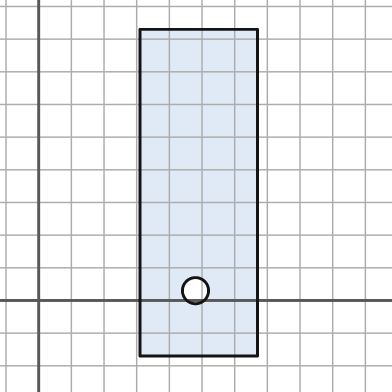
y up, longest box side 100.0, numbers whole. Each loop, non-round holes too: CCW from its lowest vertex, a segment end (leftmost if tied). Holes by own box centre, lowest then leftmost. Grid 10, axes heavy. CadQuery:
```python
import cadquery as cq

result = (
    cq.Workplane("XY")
    .moveTo(31.0, -17.0)
    .lineTo(67.0, -17.0)
    .lineTo(67.0, 83.0)
    .lineTo(31.0, 83.0)
    .close()
    .moveTo(48.0, 3.0)
    .circle(4.0)
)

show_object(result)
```